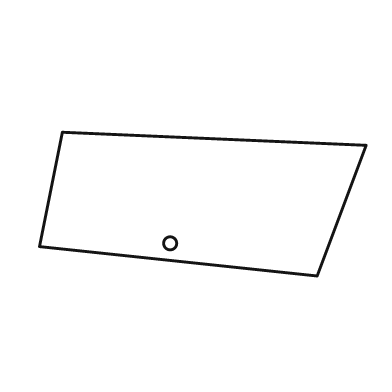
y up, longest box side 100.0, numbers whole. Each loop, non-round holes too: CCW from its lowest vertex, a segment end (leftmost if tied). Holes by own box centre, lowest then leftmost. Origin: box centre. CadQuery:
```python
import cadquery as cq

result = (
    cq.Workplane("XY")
    .moveTo(35.0, -22.0)
    .lineTo(50.0, 18.0)
    .lineTo(-43.0, 22.0)
    .lineTo(-50.0, -13.0)
    .close()
    .moveTo(-10.0, -12.0)
    .circle(2.0)
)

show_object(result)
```